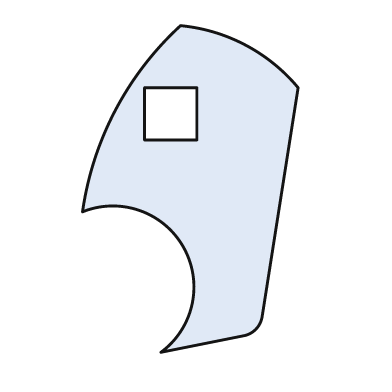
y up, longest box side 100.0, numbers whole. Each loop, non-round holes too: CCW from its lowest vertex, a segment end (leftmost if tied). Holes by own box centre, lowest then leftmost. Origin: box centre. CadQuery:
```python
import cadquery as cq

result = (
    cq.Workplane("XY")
    .moveTo(-9.0, -50.0)
    .lineTo(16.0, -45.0)
    .threePointArc((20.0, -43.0), (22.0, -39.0))
    .lineTo(33.0, 31.0)
    .threePointArc((17.0, 44.0), (-3.0, 50.0))
    .threePointArc((-23.0, 24.0), (-33.0, -7.0))
    .threePointArc((-2.0, -18.0), (-9.0, -50.0))
    .close()
    .moveTo(-14.0, 15.0)
    .lineTo(2.0, 15.0)
    .lineTo(2.0, 31.0)
    .lineTo(-14.0, 31.0)
    .close()
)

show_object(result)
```